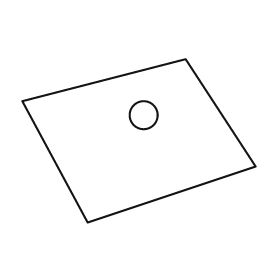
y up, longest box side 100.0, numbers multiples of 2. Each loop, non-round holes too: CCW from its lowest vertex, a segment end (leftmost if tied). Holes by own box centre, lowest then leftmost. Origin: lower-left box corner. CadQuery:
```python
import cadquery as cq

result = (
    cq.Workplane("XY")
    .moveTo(28.0, 0.0)
    .lineTo(100.0, 24.0)
    .lineTo(70.0, 70.0)
    .lineTo(0.0, 52.0)
    .close()
    .moveTo(52.0, 46.0)
    .circle(6.0)
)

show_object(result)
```